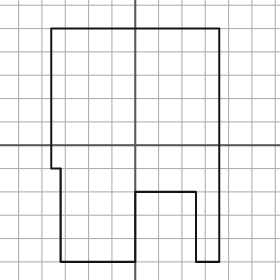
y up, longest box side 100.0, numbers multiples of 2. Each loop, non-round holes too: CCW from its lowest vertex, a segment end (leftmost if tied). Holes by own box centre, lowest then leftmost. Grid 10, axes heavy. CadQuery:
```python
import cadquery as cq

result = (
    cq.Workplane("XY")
    .moveTo(-32.0, -50.0)
    .lineTo(0.0, -50.0)
    .lineTo(0.0, -20.0)
    .lineTo(26.0, -20.0)
    .lineTo(26.0, -50.0)
    .lineTo(36.0, -50.0)
    .lineTo(36.0, 50.0)
    .lineTo(-36.0, 50.0)
    .lineTo(-36.0, -10.0)
    .lineTo(-32.0, -10.0)
    .close()
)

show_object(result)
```